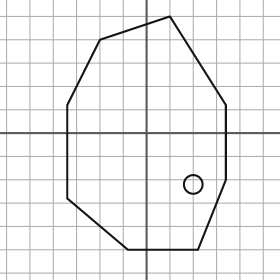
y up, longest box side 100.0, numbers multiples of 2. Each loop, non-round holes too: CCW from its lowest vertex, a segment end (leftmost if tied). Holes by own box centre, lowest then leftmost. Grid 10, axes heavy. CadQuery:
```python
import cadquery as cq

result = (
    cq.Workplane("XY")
    .moveTo(-8.0, -50.0)
    .lineTo(22.0, -50.0)
    .lineTo(34.0, -20.0)
    .lineTo(34.0, 12.0)
    .lineTo(10.0, 50.0)
    .lineTo(-20.0, 40.0)
    .lineTo(-34.0, 12.0)
    .lineTo(-34.0, -28.0)
    .close()
    .moveTo(20.0, -22.0)
    .circle(4.0)
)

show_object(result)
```